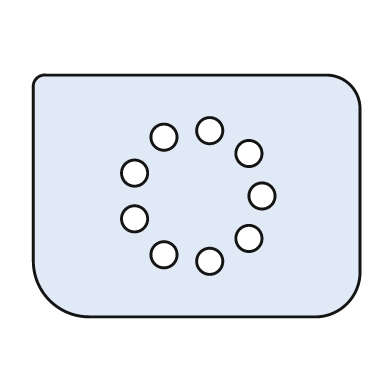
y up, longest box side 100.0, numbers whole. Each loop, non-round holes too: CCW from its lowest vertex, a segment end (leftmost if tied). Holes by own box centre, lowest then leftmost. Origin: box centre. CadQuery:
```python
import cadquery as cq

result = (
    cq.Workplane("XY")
    .moveTo(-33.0, -37.0)
    .lineTo(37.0, -37.0)
    .threePointArc((46.0, -33.0), (50.0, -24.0))
    .lineTo(50.0, 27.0)
    .threePointArc((47.0, 34.0), (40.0, 37.0))
    .lineTo(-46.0, 37.0)
    .threePointArc((-49.0, 36.0), (-50.0, 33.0))
    .lineTo(-50.0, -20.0)
    .threePointArc((-45.0, -32.0), (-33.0, -37.0))
    .close()
    .moveTo(4.0, -20.0)
    .circle(4.0)
    .moveTo(-10.0, -18.0)
    .circle(4.0)
    .moveTo(16.0, -13.0)
    .circle(4.0)
    .moveTo(-19.0, -7.0)
    .circle(4.0)
    .moveTo(20.0, 0.0)
    .circle(4.0)
    .moveTo(-19.0, 7.0)
    .circle(4.0)
    .moveTo(16.0, 13.0)
    .circle(4.0)
    .moveTo(-10.0, 18.0)
    .circle(4.0)
    .moveTo(4.0, 20.0)
    .circle(4.0)
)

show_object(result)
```